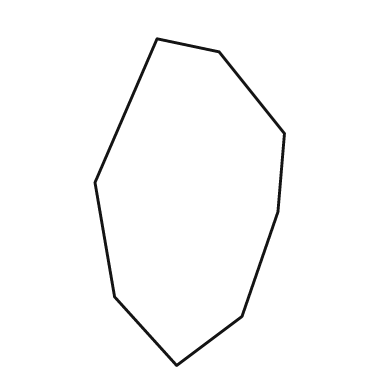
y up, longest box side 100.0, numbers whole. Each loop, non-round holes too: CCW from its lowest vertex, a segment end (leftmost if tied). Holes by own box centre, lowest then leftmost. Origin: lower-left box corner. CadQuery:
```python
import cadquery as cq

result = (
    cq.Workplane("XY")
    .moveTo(25.0, 0.0)
    .lineTo(45.0, 15.0)
    .lineTo(56.0, 47.0)
    .lineTo(58.0, 71.0)
    .lineTo(38.0, 96.0)
    .lineTo(19.0, 100.0)
    .lineTo(0.0, 56.0)
    .lineTo(6.0, 21.0)
    .close()
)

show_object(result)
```